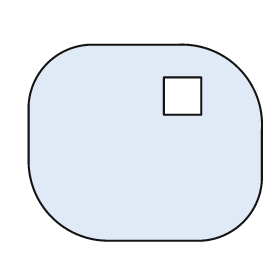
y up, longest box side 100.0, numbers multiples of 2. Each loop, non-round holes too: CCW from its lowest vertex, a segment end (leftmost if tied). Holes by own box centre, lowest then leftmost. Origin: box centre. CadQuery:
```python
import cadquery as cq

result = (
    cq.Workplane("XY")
    .moveTo(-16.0, -42.0)
    .lineTo(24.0, -42.0)
    .threePointArc((42.0, -34.0), (50.0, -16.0))
    .lineTo(50.0, 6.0)
    .threePointArc((40.0, 32.0), (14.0, 42.0))
    .lineTo(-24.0, 42.0)
    .threePointArc((-42.0, 34.0), (-50.0, 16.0))
    .lineTo(-50.0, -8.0)
    .threePointArc((-40.0, -32.0), (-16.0, -42.0))
    .close()
    .moveTo(8.0, 12.0)
    .lineTo(24.0, 12.0)
    .lineTo(24.0, 28.0)
    .lineTo(8.0, 28.0)
    .close()
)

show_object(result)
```